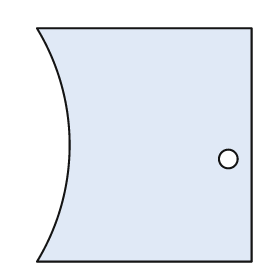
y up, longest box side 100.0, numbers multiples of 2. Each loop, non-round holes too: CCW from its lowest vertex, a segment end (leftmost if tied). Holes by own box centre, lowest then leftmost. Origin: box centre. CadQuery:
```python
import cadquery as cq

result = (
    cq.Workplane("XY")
    .moveTo(-46.0, -50.0)
    .lineTo(46.0, -50.0)
    .lineTo(46.0, 50.0)
    .lineTo(-46.0, 50.0)
    .threePointArc((-32.0, 0.0), (-46.0, -50.0))
    .close()
    .moveTo(36.0, -6.0)
    .circle(4.0)
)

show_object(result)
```